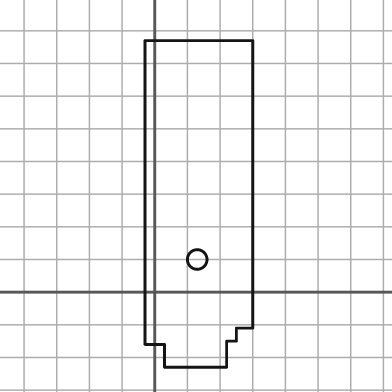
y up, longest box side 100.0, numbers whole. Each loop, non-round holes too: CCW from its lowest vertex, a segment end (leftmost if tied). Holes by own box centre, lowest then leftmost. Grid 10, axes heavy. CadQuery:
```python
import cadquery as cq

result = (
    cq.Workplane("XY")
    .moveTo(3.0, -23.0)
    .lineTo(22.0, -23.0)
    .lineTo(22.0, -15.0)
    .lineTo(25.0, -15.0)
    .lineTo(25.0, -11.0)
    .lineTo(30.0, -11.0)
    .lineTo(30.0, 77.0)
    .lineTo(-3.0, 77.0)
    .lineTo(-3.0, -16.0)
    .lineTo(3.0, -16.0)
    .close()
    .moveTo(13.0, 10.0)
    .circle(3.0)
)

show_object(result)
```